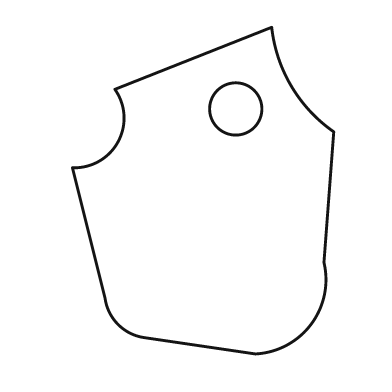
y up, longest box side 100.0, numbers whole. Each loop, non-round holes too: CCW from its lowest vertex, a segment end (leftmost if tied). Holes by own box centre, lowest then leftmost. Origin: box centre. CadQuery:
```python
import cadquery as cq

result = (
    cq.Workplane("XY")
    .moveTo(16.0, -50.0)
    .threePointArc((33.0, -41.0), (37.0, -22.0))
    .lineTo(40.0, 18.0)
    .threePointArc((27.0, 32.0), (21.0, 50.0))
    .lineTo(-27.0, 31.0)
    .threePointArc((-26.0, 15.0), (-40.0, 7.0))
    .lineTo(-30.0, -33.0)
    .threePointArc((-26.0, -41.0), (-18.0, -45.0))
    .close()
    .moveTo(10.0, 25.0)
    .circle(8.0)
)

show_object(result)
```